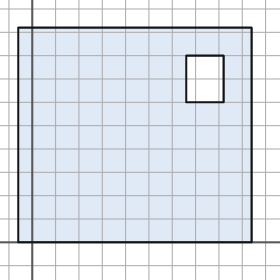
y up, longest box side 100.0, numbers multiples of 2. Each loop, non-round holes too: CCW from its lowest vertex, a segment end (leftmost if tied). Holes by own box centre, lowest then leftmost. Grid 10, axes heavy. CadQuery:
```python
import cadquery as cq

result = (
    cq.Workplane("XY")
    .moveTo(-6.0, 0.0)
    .lineTo(94.0, 0.0)
    .lineTo(94.0, 92.0)
    .lineTo(-6.0, 92.0)
    .close()
    .moveTo(66.0, 60.0)
    .lineTo(82.0, 60.0)
    .lineTo(82.0, 80.0)
    .lineTo(66.0, 80.0)
    .close()
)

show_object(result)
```